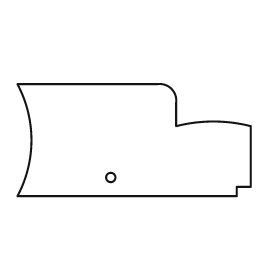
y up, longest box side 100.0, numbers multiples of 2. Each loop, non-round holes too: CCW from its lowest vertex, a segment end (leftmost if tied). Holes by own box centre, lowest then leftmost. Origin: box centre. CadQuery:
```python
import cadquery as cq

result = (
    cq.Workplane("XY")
    .moveTo(-50.0, -24.0)
    .lineTo(44.0, -24.0)
    .lineTo(44.0, -20.0)
    .lineTo(50.0, -20.0)
    .lineTo(50.0, 6.0)
    .threePointArc((34.0, 8.0), (18.0, 6.0))
    .lineTo(18.0, 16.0)
    .threePointArc((16.0, 22.0), (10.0, 24.0))
    .lineTo(-50.0, 24.0)
    .threePointArc((-44.0, 0.0), (-50.0, -24.0))
    .close()
    .moveTo(-10.0, -16.0)
    .circle(2.0)
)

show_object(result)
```